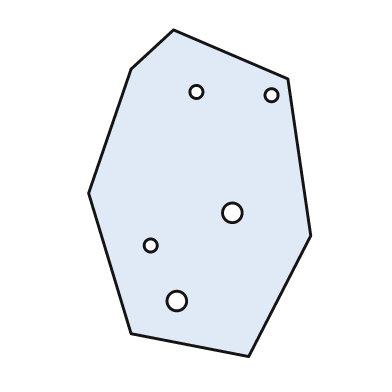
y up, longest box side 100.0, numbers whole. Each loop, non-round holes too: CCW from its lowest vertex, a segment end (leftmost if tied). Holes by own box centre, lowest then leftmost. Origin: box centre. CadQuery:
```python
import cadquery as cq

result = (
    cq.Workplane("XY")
    .moveTo(15.0, -50.0)
    .lineTo(34.0, -13.0)
    .lineTo(27.0, 35.0)
    .lineTo(-8.0, 50.0)
    .lineTo(-21.0, 38.0)
    .lineTo(-34.0, 0.0)
    .lineTo(-21.0, -43.0)
    .close()
    .moveTo(-7.0, -33.0)
    .circle(3.0)
    .moveTo(-15.0, -16.0)
    .circle(2.0)
    .moveTo(10.0, -6.0)
    .circle(3.0)
    .moveTo(22.0, 30.0)
    .circle(2.0)
    .moveTo(-1.0, 31.0)
    .circle(2.0)
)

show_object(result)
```